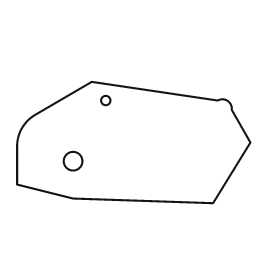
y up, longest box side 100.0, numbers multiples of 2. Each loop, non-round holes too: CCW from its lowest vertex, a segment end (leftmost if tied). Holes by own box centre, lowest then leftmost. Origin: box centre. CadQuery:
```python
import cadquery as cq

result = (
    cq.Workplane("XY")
    .moveTo(34.0, -26.0)
    .lineTo(50.0, 0.0)
    .lineTo(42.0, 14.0)
    .threePointArc((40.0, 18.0), (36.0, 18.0))
    .lineTo(-18.0, 26.0)
    .lineTo(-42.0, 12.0)
    .threePointArc((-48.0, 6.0), (-50.0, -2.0))
    .lineTo(-50.0, -18.0)
    .lineTo(-26.0, -24.0)
    .close()
    .moveTo(-26.0, -8.0)
    .circle(4.0)
    .moveTo(-12.0, 18.0)
    .circle(2.0)
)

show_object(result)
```